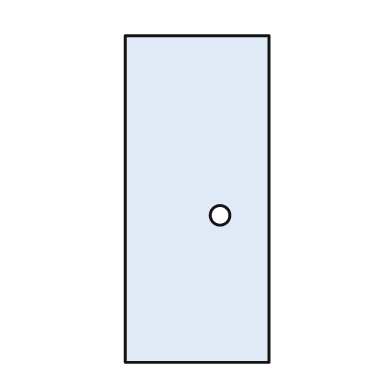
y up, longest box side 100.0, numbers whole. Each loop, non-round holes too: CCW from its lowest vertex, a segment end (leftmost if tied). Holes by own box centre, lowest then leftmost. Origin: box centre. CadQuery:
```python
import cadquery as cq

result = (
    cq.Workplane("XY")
    .moveTo(-22.0, -50.0)
    .lineTo(22.0, -50.0)
    .lineTo(22.0, 50.0)
    .lineTo(-22.0, 50.0)
    .close()
    .moveTo(7.0, -5.0)
    .circle(3.0)
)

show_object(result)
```